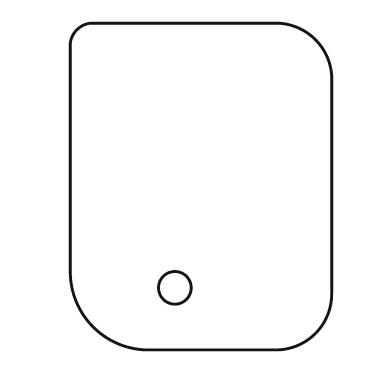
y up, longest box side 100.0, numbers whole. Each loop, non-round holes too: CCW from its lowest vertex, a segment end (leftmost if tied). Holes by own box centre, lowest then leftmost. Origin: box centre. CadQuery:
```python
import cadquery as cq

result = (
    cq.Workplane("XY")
    .moveTo(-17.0, -50.0)
    .lineTo(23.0, -50.0)
    .threePointArc((35.0, -45.0), (40.0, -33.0))
    .lineTo(40.0, 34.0)
    .threePointArc((35.0, 45.0), (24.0, 50.0))
    .lineTo(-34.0, 50.0)
    .threePointArc((-38.0, 48.0), (-40.0, 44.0))
    .lineTo(-40.0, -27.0)
    .threePointArc((-33.0, -43.0), (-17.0, -50.0))
    .close()
    .moveTo(-8.0, -31.0)
    .circle(5.0)
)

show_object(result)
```